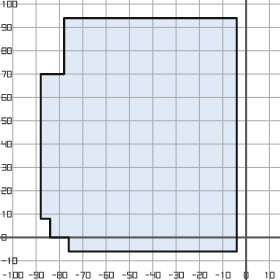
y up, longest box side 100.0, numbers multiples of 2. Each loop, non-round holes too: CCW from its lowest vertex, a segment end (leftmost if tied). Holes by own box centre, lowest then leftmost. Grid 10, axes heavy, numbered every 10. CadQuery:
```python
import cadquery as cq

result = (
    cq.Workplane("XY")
    .moveTo(-76.0, -6.0)
    .lineTo(-4.0, -6.0)
    .lineTo(-4.0, 94.0)
    .lineTo(-78.0, 94.0)
    .lineTo(-78.0, 70.0)
    .lineTo(-88.0, 70.0)
    .lineTo(-88.0, 8.0)
    .lineTo(-84.0, 8.0)
    .lineTo(-84.0, 0.0)
    .lineTo(-76.0, 0.0)
    .close()
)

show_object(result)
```